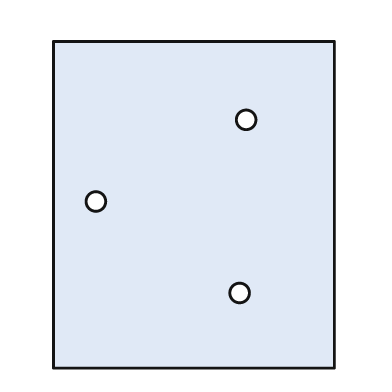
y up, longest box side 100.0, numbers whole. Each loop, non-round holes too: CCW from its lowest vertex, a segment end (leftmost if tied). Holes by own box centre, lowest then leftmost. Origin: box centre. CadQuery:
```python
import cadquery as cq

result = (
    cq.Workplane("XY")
    .moveTo(-43.0, -50.0)
    .lineTo(43.0, -50.0)
    .lineTo(43.0, 50.0)
    .lineTo(-43.0, 50.0)
    .close()
    .moveTo(14.0, -27.0)
    .circle(3.0)
    .moveTo(-30.0, 1.0)
    .circle(3.0)
    .moveTo(16.0, 26.0)
    .circle(3.0)
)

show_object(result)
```